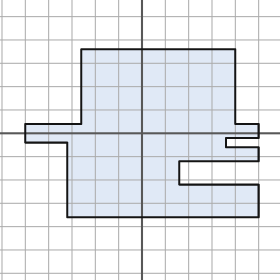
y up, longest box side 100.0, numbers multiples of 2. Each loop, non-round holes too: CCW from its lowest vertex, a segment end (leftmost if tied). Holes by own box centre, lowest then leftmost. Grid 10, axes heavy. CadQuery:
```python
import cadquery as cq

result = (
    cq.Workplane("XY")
    .moveTo(-32.0, -36.0)
    .lineTo(50.0, -36.0)
    .lineTo(50.0, -22.0)
    .lineTo(16.0, -22.0)
    .lineTo(16.0, -12.0)
    .lineTo(50.0, -12.0)
    .lineTo(50.0, -6.0)
    .lineTo(36.0, -6.0)
    .lineTo(36.0, -2.0)
    .lineTo(50.0, -2.0)
    .lineTo(50.0, 4.0)
    .lineTo(40.0, 4.0)
    .lineTo(40.0, 36.0)
    .lineTo(-26.0, 36.0)
    .lineTo(-26.0, 4.0)
    .lineTo(-50.0, 4.0)
    .lineTo(-50.0, -4.0)
    .lineTo(-32.0, -4.0)
    .close()
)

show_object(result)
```